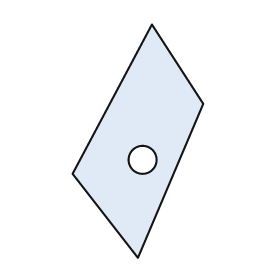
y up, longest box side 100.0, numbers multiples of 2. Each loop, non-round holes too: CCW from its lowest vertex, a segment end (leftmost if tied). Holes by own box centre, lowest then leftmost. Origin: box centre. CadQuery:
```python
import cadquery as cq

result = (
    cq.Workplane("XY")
    .moveTo(0.0, -50.0)
    .lineTo(28.0, 16.0)
    .lineTo(6.0, 50.0)
    .lineTo(-28.0, -14.0)
    .close()
    .moveTo(2.0, -8.0)
    .circle(6.0)
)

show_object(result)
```